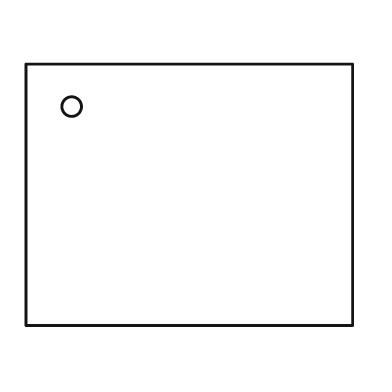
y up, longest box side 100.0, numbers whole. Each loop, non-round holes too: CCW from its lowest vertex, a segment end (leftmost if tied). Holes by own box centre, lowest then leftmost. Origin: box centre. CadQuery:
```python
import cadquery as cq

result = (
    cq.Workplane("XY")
    .moveTo(-50.0, -40.0)
    .lineTo(50.0, -40.0)
    .lineTo(50.0, 40.0)
    .lineTo(-50.0, 40.0)
    .close()
    .moveTo(-36.0, 27.0)
    .circle(3.0)
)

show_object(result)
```